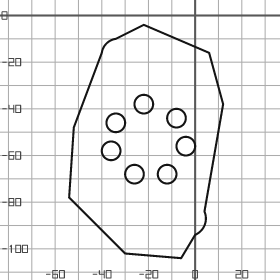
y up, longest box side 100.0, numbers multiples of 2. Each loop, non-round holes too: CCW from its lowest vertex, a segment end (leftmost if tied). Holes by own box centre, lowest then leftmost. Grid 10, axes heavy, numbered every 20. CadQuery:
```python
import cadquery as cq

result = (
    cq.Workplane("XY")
    .moveTo(-6.0, -104.0)
    .lineTo(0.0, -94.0)
    .threePointArc((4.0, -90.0), (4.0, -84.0))
    .lineTo(12.0, -38.0)
    .lineTo(6.0, -16.0)
    .lineTo(-22.0, -4.0)
    .lineTo(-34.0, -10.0)
    .threePointArc((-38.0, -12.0), (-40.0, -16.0))
    .lineTo(-52.0, -48.0)
    .lineTo(-54.0, -78.0)
    .lineTo(-30.0, -102.0)
    .close()
    .moveTo(-26.0, -68.0)
    .circle(4.0)
    .moveTo(-12.0, -68.0)
    .circle(4.0)
    .moveTo(-36.0, -58.0)
    .circle(4.0)
    .moveTo(-4.0, -56.0)
    .circle(4.0)
    .moveTo(-34.0, -46.0)
    .circle(4.0)
    .moveTo(-8.0, -44.0)
    .circle(4.0)
    .moveTo(-22.0, -38.0)
    .circle(4.0)
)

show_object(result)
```